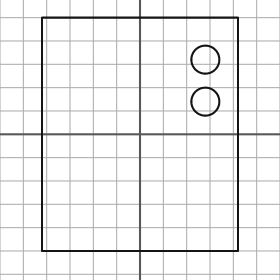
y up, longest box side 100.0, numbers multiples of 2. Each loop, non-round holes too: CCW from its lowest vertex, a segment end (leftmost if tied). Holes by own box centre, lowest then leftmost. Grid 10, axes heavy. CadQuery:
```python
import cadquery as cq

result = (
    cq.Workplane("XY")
    .moveTo(-42.0, -50.0)
    .lineTo(42.0, -50.0)
    .lineTo(42.0, 50.0)
    .lineTo(-42.0, 50.0)
    .close()
    .moveTo(28.0, 14.0)
    .circle(6.0)
    .moveTo(28.0, 32.0)
    .circle(6.0)
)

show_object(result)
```